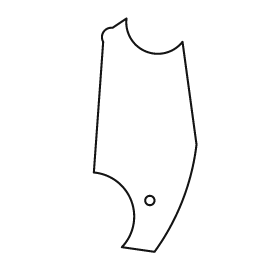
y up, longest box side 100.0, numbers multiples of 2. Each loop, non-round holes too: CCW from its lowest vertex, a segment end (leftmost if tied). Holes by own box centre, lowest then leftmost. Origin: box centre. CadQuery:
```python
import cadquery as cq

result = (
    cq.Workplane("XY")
    .moveTo(4.0, -50.0)
    .threePointArc((16.0, -28.0), (22.0, -4.0))
    .lineTo(16.0, 40.0)
    .threePointArc((0.0, 36.0), (-8.0, 50.0))
    .lineTo(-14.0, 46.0)
    .threePointArc((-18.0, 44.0), (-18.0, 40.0))
    .lineTo(-22.0, -16.0)
    .threePointArc((-6.0, -28.0), (-10.0, -48.0))
    .close()
    .moveTo(2.0, -28.0)
    .circle(2.0)
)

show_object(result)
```